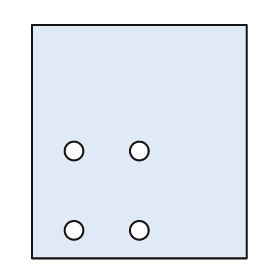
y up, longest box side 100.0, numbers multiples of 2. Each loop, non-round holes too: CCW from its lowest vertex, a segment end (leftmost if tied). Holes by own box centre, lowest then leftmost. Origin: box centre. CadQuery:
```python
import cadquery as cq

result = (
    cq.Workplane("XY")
    .moveTo(-46.0, -50.0)
    .lineTo(46.0, -50.0)
    .lineTo(46.0, 50.0)
    .lineTo(-46.0, 50.0)
    .close()
    .moveTo(-28.0, -38.0)
    .circle(4.0)
    .moveTo(0.0, -38.0)
    .circle(4.0)
    .moveTo(-28.0, -4.0)
    .circle(4.0)
    .moveTo(0.0, -4.0)
    .circle(4.0)
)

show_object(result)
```